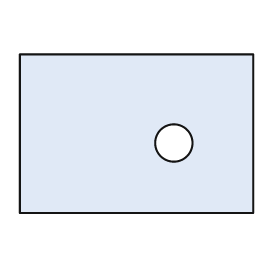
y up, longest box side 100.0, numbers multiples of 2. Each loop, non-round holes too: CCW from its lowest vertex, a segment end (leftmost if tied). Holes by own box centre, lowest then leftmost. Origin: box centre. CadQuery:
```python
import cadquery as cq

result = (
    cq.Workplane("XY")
    .moveTo(-50.0, -34.0)
    .lineTo(50.0, -34.0)
    .lineTo(50.0, 34.0)
    .lineTo(-50.0, 34.0)
    .close()
    .moveTo(16.0, -4.0)
    .circle(8.0)
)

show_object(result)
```